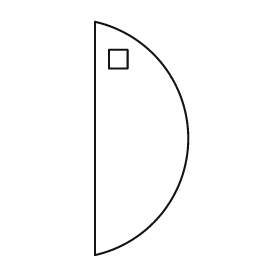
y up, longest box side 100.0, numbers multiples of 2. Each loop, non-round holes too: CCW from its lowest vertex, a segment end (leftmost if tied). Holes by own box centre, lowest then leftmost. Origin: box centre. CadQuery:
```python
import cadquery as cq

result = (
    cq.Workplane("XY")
    .moveTo(-20.0, -50.0)
    .threePointArc((20.0, 0.0), (-20.0, 50.0))
    .close()
    .moveTo(-14.0, 30.0)
    .lineTo(-6.0, 30.0)
    .lineTo(-6.0, 38.0)
    .lineTo(-14.0, 38.0)
    .close()
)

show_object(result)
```